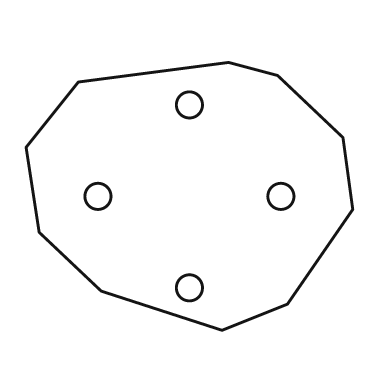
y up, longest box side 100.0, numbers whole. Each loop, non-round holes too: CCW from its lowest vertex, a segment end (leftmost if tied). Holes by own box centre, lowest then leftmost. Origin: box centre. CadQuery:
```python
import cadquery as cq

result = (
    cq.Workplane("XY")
    .moveTo(10.0, -41.0)
    .lineTo(30.0, -33.0)
    .lineTo(50.0, -4.0)
    .lineTo(47.0, 18.0)
    .lineTo(27.0, 37.0)
    .lineTo(12.0, 41.0)
    .lineTo(-34.0, 35.0)
    .lineTo(-50.0, 15.0)
    .lineTo(-46.0, -11.0)
    .lineTo(-27.0, -29.0)
    .close()
    .moveTo(0.0, -28.0)
    .circle(4.0)
    .moveTo(-28.0, 0.0)
    .circle(4.0)
    .moveTo(28.0, 0.0)
    .circle(4.0)
    .moveTo(0.0, 28.0)
    .circle(4.0)
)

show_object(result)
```